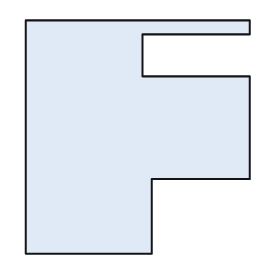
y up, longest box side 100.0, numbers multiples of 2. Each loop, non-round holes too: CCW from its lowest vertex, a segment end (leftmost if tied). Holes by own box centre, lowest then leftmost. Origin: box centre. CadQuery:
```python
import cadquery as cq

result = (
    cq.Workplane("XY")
    .moveTo(-48.0, -50.0)
    .lineTo(6.0, -50.0)
    .lineTo(6.0, -18.0)
    .lineTo(48.0, -18.0)
    .lineTo(48.0, 26.0)
    .lineTo(2.0, 26.0)
    .lineTo(2.0, 44.0)
    .lineTo(48.0, 44.0)
    .lineTo(48.0, 50.0)
    .lineTo(-48.0, 50.0)
    .close()
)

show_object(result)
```